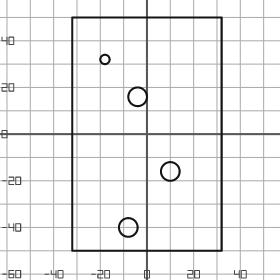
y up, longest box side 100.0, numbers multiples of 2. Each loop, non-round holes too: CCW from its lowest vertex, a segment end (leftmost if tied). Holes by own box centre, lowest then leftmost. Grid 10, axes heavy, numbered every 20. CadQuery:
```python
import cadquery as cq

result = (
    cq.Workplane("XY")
    .moveTo(-32.0, -50.0)
    .lineTo(32.0, -50.0)
    .lineTo(32.0, 50.0)
    .lineTo(-32.0, 50.0)
    .close()
    .moveTo(-8.0, -40.0)
    .circle(4.0)
    .moveTo(10.0, -16.0)
    .circle(4.0)
    .moveTo(-4.0, 16.0)
    .circle(4.0)
    .moveTo(-18.0, 32.0)
    .circle(2.0)
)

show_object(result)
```